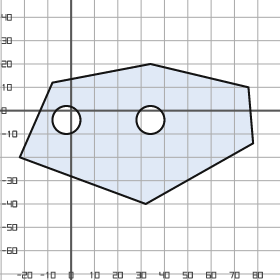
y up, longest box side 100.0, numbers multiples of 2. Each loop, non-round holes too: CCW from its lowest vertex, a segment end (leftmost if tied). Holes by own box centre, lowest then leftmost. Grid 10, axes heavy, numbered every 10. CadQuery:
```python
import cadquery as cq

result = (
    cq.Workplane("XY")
    .moveTo(32.0, -40.0)
    .lineTo(78.0, -14.0)
    .lineTo(76.0, 10.0)
    .lineTo(34.0, 20.0)
    .lineTo(-8.0, 12.0)
    .lineTo(-22.0, -20.0)
    .close()
    .moveTo(-2.0, -4.0)
    .circle(6.0)
    .moveTo(34.0, -4.0)
    .circle(6.0)
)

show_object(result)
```